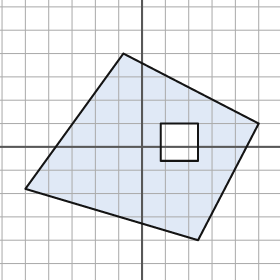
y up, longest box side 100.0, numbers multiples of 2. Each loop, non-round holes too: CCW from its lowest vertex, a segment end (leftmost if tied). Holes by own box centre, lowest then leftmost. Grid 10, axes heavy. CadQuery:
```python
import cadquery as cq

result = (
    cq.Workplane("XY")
    .moveTo(24.0, -40.0)
    .lineTo(50.0, 10.0)
    .lineTo(-8.0, 40.0)
    .lineTo(-50.0, -18.0)
    .close()
    .moveTo(8.0, -6.0)
    .lineTo(24.0, -6.0)
    .lineTo(24.0, 10.0)
    .lineTo(8.0, 10.0)
    .close()
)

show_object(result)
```